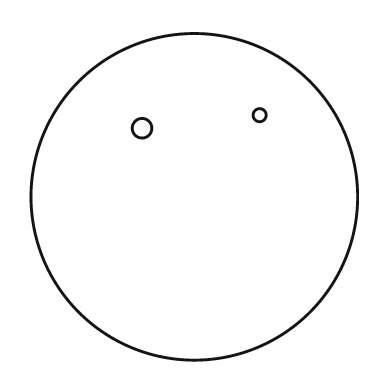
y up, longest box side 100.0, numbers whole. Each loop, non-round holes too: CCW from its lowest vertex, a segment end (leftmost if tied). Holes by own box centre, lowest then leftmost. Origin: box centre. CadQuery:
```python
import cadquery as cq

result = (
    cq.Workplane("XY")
    .moveTo(0.0, 0.0)
    .circle(50.0)
    .moveTo(-16.0, 21.0)
    .circle(3.0)
    .moveTo(20.0, 25.0)
    .circle(2.0)
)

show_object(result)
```